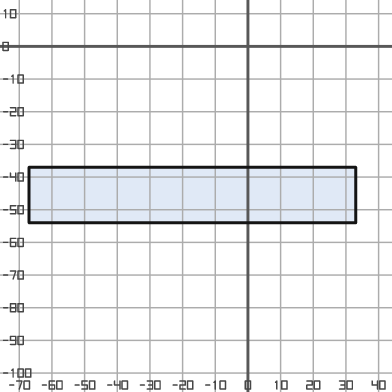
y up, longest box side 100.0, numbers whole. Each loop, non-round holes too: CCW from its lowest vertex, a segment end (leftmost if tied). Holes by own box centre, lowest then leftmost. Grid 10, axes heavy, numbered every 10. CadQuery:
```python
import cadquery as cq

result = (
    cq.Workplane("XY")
    .moveTo(-67.0, -54.0)
    .lineTo(33.0, -54.0)
    .lineTo(33.0, -37.0)
    .lineTo(-67.0, -37.0)
    .close()
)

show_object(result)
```